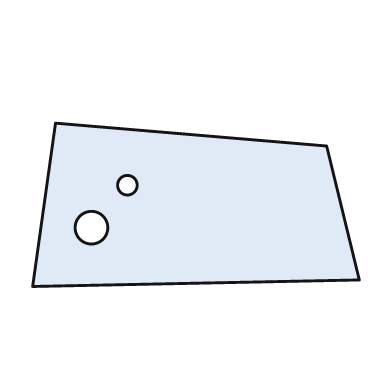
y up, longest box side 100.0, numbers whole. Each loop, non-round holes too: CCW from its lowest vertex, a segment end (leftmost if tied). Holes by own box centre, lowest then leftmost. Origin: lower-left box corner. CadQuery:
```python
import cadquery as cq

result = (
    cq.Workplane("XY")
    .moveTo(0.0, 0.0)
    .lineTo(100.0, 2.0)
    .lineTo(90.0, 43.0)
    .lineTo(7.0, 50.0)
    .close()
    .moveTo(18.0, 18.0)
    .circle(5.0)
    .moveTo(29.0, 31.0)
    .circle(3.0)
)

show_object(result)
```